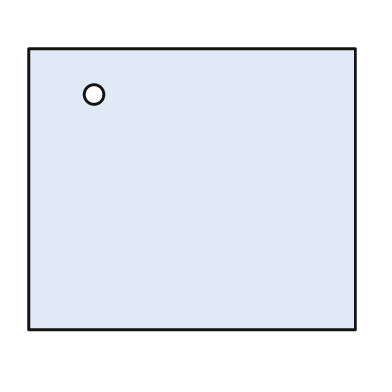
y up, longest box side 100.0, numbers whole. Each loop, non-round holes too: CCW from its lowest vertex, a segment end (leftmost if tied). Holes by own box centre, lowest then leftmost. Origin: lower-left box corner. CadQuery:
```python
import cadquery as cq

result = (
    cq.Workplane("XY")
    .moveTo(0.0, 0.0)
    .lineTo(100.0, 0.0)
    .lineTo(100.0, 86.0)
    .lineTo(0.0, 86.0)
    .close()
    .moveTo(20.0, 72.0)
    .circle(3.0)
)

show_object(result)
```